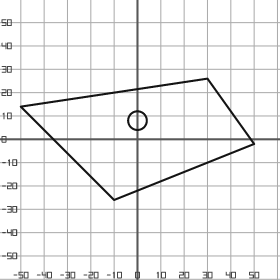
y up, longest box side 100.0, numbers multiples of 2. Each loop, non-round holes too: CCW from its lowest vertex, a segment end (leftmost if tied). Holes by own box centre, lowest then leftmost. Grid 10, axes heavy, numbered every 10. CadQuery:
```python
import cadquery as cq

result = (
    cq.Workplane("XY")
    .moveTo(-10.0, -26.0)
    .lineTo(50.0, -2.0)
    .lineTo(30.0, 26.0)
    .lineTo(-50.0, 14.0)
    .close()
    .moveTo(0.0, 8.0)
    .circle(4.0)
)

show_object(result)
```